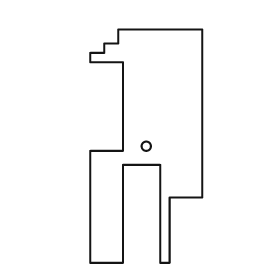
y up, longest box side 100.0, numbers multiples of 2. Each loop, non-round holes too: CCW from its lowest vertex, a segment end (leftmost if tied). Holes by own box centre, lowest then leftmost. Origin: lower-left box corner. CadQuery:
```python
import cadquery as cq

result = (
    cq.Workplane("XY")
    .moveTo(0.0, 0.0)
    .lineTo(14.0, 0.0)
    .lineTo(14.0, 42.0)
    .lineTo(30.0, 42.0)
    .lineTo(30.0, 0.0)
    .lineTo(34.0, 0.0)
    .lineTo(34.0, 28.0)
    .lineTo(48.0, 28.0)
    .lineTo(48.0, 100.0)
    .lineTo(12.0, 100.0)
    .lineTo(12.0, 94.0)
    .lineTo(6.0, 94.0)
    .lineTo(6.0, 90.0)
    .lineTo(0.0, 90.0)
    .lineTo(0.0, 86.0)
    .lineTo(14.0, 86.0)
    .lineTo(14.0, 48.0)
    .lineTo(0.0, 48.0)
    .close()
    .moveTo(24.0, 50.0)
    .circle(2.0)
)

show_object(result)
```